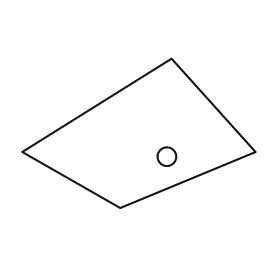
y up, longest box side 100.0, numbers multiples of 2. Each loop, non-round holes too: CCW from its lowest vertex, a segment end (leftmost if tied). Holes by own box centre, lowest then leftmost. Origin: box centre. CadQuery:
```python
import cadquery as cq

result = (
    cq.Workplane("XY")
    .moveTo(-8.0, -32.0)
    .lineTo(50.0, -8.0)
    .lineTo(14.0, 32.0)
    .lineTo(-50.0, -8.0)
    .close()
    .moveTo(12.0, -10.0)
    .circle(4.0)
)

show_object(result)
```